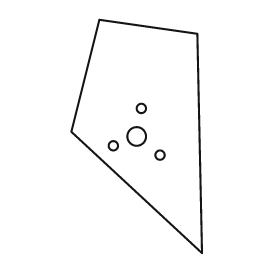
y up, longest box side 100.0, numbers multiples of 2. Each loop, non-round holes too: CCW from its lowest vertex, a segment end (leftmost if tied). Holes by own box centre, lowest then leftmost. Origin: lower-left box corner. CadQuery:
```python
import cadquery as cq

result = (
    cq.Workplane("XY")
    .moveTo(56.0, 0.0)
    .lineTo(54.0, 94.0)
    .lineTo(12.0, 100.0)
    .lineTo(0.0, 52.0)
    .close()
    .moveTo(38.0, 42.0)
    .circle(2.0)
    .moveTo(18.0, 46.0)
    .circle(2.0)
    .moveTo(28.0, 50.0)
    .circle(4.0)
    .moveTo(30.0, 62.0)
    .circle(2.0)
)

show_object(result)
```